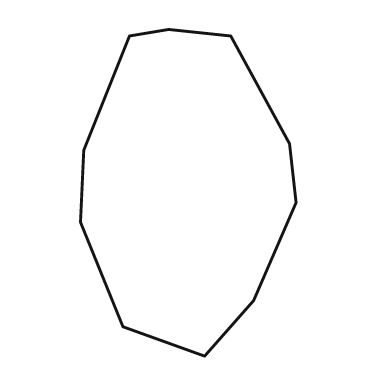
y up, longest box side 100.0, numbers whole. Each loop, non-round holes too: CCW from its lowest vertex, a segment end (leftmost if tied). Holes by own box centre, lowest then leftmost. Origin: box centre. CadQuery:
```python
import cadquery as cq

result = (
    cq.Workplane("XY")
    .moveTo(5.0, -50.0)
    .lineTo(20.0, -33.0)
    .lineTo(33.0, -3.0)
    .lineTo(31.0, 15.0)
    .lineTo(13.0, 48.0)
    .lineTo(-6.0, 50.0)
    .lineTo(-18.0, 48.0)
    .lineTo(-32.0, 13.0)
    .lineTo(-33.0, -9.0)
    .lineTo(-20.0, -41.0)
    .close()
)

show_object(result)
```